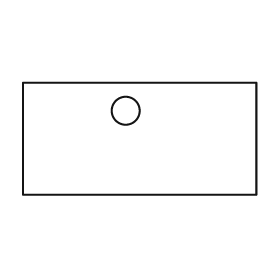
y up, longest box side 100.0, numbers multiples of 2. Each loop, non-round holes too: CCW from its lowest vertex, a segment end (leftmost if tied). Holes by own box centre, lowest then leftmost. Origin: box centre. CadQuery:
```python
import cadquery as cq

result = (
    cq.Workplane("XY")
    .moveTo(-50.0, -24.0)
    .lineTo(50.0, -24.0)
    .lineTo(50.0, 24.0)
    .lineTo(-50.0, 24.0)
    .close()
    .moveTo(-6.0, 12.0)
    .circle(6.0)
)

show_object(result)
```